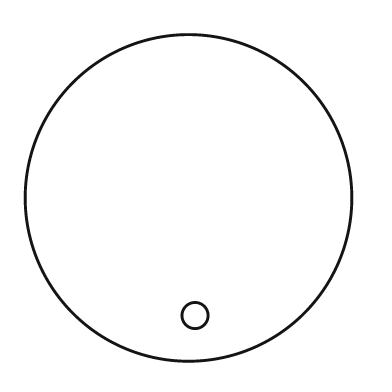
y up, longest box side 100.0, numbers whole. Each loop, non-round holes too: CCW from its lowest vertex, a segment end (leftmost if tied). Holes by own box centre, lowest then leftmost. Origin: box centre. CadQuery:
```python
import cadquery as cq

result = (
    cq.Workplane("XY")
    .moveTo(0.0, 0.0)
    .circle(50.0)
    .moveTo(2.0, -36.0)
    .circle(4.0)
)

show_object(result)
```